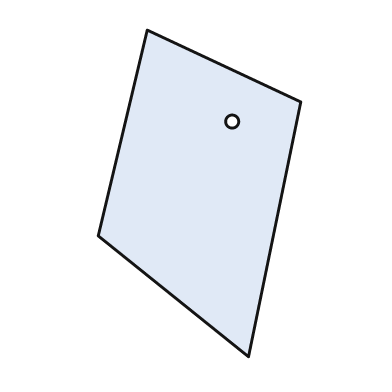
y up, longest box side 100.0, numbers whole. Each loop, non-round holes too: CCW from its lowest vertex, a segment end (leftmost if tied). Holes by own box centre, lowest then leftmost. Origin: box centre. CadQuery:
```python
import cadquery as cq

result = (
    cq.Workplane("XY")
    .moveTo(15.0, -50.0)
    .lineTo(31.0, 28.0)
    .lineTo(-16.0, 50.0)
    .lineTo(-31.0, -13.0)
    .close()
    .moveTo(10.0, 22.0)
    .circle(2.0)
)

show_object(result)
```